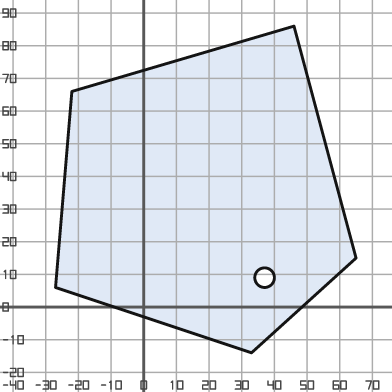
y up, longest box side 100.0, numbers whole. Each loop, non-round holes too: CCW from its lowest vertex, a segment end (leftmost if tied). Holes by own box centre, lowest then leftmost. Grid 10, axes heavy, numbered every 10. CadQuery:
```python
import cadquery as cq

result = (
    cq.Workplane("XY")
    .moveTo(33.0, -14.0)
    .lineTo(65.0, 15.0)
    .lineTo(46.0, 86.0)
    .lineTo(-22.0, 66.0)
    .lineTo(-27.0, 6.0)
    .close()
    .moveTo(37.0, 9.0)
    .circle(3.0)
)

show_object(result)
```